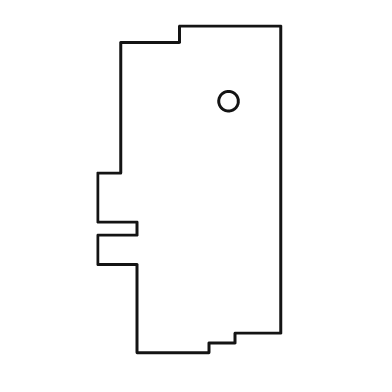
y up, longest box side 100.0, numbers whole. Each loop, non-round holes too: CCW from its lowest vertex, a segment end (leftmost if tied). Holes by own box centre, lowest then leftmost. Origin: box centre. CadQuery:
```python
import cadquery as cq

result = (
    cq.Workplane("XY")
    .moveTo(-16.0, -50.0)
    .lineTo(6.0, -50.0)
    .lineTo(6.0, -47.0)
    .lineTo(14.0, -47.0)
    .lineTo(14.0, -44.0)
    .lineTo(28.0, -44.0)
    .lineTo(28.0, 50.0)
    .lineTo(-3.0, 50.0)
    .lineTo(-3.0, 45.0)
    .lineTo(-21.0, 45.0)
    .lineTo(-21.0, 5.0)
    .lineTo(-28.0, 5.0)
    .lineTo(-28.0, -10.0)
    .lineTo(-16.0, -10.0)
    .lineTo(-16.0, -14.0)
    .lineTo(-28.0, -14.0)
    .lineTo(-28.0, -23.0)
    .lineTo(-16.0, -23.0)
    .close()
    .moveTo(12.0, 27.0)
    .circle(3.0)
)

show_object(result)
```